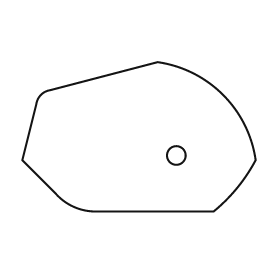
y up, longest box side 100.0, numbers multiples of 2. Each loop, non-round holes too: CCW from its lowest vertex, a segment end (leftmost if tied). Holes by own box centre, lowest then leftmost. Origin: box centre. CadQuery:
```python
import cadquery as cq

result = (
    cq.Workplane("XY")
    .moveTo(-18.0, -32.0)
    .lineTo(32.0, -32.0)
    .threePointArc((42.0, -22.0), (50.0, -10.0))
    .threePointArc((36.0, 18.0), (8.0, 32.0))
    .lineTo(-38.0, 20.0)
    .threePointArc((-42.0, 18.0), (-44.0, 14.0))
    .lineTo(-50.0, -10.0)
    .lineTo(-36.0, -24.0)
    .threePointArc((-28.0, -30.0), (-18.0, -32.0))
    .close()
    .moveTo(16.0, -8.0)
    .circle(4.0)
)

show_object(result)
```